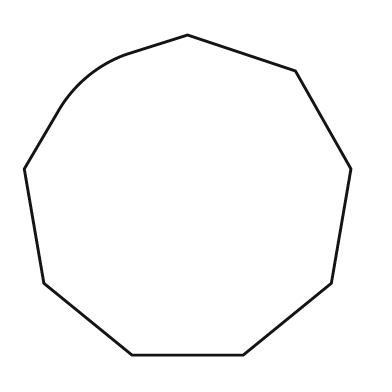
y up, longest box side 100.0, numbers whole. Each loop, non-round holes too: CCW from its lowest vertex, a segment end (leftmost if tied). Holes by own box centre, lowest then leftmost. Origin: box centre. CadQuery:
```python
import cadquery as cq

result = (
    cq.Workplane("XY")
    .moveTo(-17.0, -49.0)
    .lineTo(17.0, -49.0)
    .lineTo(44.0, -27.0)
    .lineTo(50.0, 8.0)
    .lineTo(33.0, 38.0)
    .lineTo(0.0, 49.0)
    .lineTo(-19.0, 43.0)
    .threePointArc((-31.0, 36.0), (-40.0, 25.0))
    .lineTo(-50.0, 8.0)
    .lineTo(-44.0, -27.0)
    .close()
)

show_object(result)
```